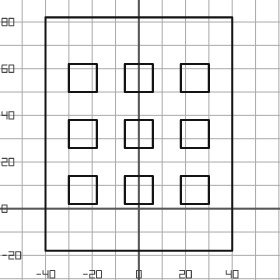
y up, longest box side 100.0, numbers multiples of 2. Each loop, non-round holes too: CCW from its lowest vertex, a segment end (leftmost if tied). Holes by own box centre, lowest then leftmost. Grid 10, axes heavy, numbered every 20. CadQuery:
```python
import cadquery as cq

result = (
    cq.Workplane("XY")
    .moveTo(-40.0, -18.0)
    .lineTo(40.0, -18.0)
    .lineTo(40.0, 82.0)
    .lineTo(-40.0, 82.0)
    .close()
    .moveTo(-30.0, 2.0)
    .lineTo(-18.0, 2.0)
    .lineTo(-18.0, 14.0)
    .lineTo(-30.0, 14.0)
    .close()
    .moveTo(-6.0, 2.0)
    .lineTo(6.0, 2.0)
    .lineTo(6.0, 14.0)
    .lineTo(-6.0, 14.0)
    .close()
    .moveTo(18.0, 2.0)
    .lineTo(30.0, 2.0)
    .lineTo(30.0, 14.0)
    .lineTo(18.0, 14.0)
    .close()
    .moveTo(-30.0, 26.0)
    .lineTo(-18.0, 26.0)
    .lineTo(-18.0, 38.0)
    .lineTo(-30.0, 38.0)
    .close()
    .moveTo(-6.0, 26.0)
    .lineTo(6.0, 26.0)
    .lineTo(6.0, 38.0)
    .lineTo(-6.0, 38.0)
    .close()
    .moveTo(18.0, 26.0)
    .lineTo(30.0, 26.0)
    .lineTo(30.0, 38.0)
    .lineTo(18.0, 38.0)
    .close()
    .moveTo(-30.0, 50.0)
    .lineTo(-18.0, 50.0)
    .lineTo(-18.0, 62.0)
    .lineTo(-30.0, 62.0)
    .close()
    .moveTo(-6.0, 50.0)
    .lineTo(6.0, 50.0)
    .lineTo(6.0, 62.0)
    .lineTo(-6.0, 62.0)
    .close()
    .moveTo(18.0, 50.0)
    .lineTo(30.0, 50.0)
    .lineTo(30.0, 62.0)
    .lineTo(18.0, 62.0)
    .close()
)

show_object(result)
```